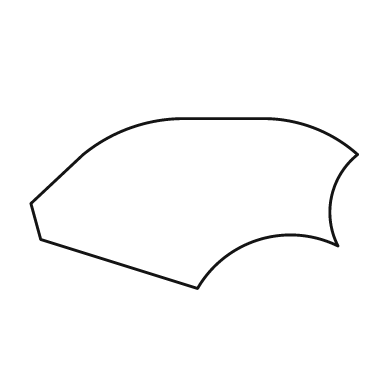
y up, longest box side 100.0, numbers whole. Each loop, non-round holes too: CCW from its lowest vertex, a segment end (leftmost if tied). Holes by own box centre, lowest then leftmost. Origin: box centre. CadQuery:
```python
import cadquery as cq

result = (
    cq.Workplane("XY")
    .moveTo(1.0, -26.0)
    .threePointArc((20.0, -11.0), (44.0, -13.0))
    .threePointArc((42.0, 2.0), (50.0, 15.0))
    .threePointArc((37.0, 23.0), (22.0, 26.0))
    .lineTo(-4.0, 26.0)
    .threePointArc((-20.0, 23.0), (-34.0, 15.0))
    .lineTo(-50.0, 0.0)
    .lineTo(-47.0, -11.0)
    .close()
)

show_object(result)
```